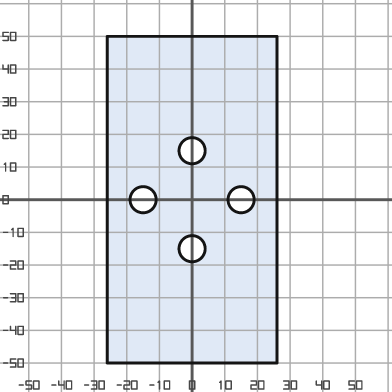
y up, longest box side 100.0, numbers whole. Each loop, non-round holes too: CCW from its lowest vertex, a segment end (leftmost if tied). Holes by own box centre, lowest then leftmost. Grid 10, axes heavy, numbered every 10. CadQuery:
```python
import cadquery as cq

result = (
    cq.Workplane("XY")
    .moveTo(-26.0, -50.0)
    .lineTo(26.0, -50.0)
    .lineTo(26.0, 50.0)
    .lineTo(-26.0, 50.0)
    .close()
    .moveTo(0.0, -15.0)
    .circle(4.0)
    .moveTo(-15.0, 0.0)
    .circle(4.0)
    .moveTo(15.0, 0.0)
    .circle(4.0)
    .moveTo(0.0, 15.0)
    .circle(4.0)
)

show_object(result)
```